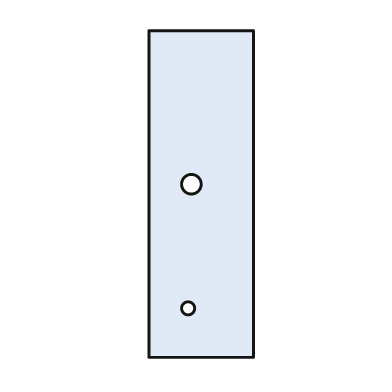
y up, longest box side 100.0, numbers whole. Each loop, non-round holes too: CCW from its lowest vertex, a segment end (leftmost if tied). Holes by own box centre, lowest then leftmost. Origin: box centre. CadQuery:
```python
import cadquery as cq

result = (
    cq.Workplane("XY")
    .moveTo(-16.0, -50.0)
    .lineTo(16.0, -50.0)
    .lineTo(16.0, 50.0)
    .lineTo(-16.0, 50.0)
    .close()
    .moveTo(-4.0, -35.0)
    .circle(2.0)
    .moveTo(-3.0, 3.0)
    .circle(3.0)
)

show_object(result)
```